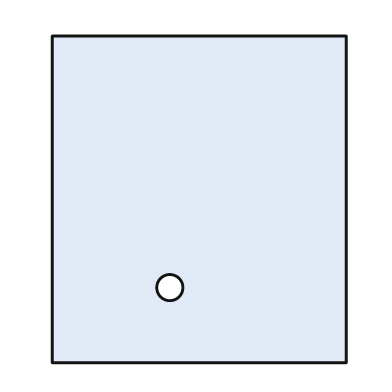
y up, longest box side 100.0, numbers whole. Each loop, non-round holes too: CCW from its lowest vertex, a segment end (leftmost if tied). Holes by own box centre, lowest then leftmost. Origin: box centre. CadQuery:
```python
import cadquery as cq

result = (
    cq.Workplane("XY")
    .moveTo(-45.0, -50.0)
    .lineTo(45.0, -50.0)
    .lineTo(45.0, 50.0)
    .lineTo(-45.0, 50.0)
    .close()
    .moveTo(-9.0, -27.0)
    .circle(4.0)
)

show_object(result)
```